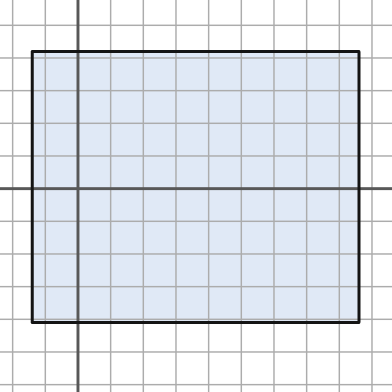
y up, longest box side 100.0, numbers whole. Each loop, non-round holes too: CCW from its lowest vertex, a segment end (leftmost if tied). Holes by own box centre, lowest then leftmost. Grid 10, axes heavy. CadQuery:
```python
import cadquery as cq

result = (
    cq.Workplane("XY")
    .moveTo(-14.0, -41.0)
    .lineTo(86.0, -41.0)
    .lineTo(86.0, 42.0)
    .lineTo(-14.0, 42.0)
    .close()
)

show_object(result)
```